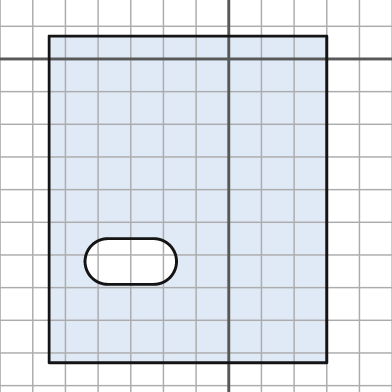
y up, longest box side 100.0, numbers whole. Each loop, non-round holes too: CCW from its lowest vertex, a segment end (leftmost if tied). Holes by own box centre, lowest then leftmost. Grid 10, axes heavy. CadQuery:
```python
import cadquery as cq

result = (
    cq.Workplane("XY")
    .moveTo(-55.0, -93.0)
    .lineTo(30.0, -93.0)
    .lineTo(30.0, 7.0)
    .lineTo(-55.0, 7.0)
    .close()
    .moveTo(-37.0, -69.0)
    .lineTo(-23.0, -69.0)
    .threePointArc((-16.0, -62.0), (-23.0, -55.0))
    .lineTo(-37.0, -55.0)
    .threePointArc((-44.0, -62.0), (-37.0, -69.0))
    .close()
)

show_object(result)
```